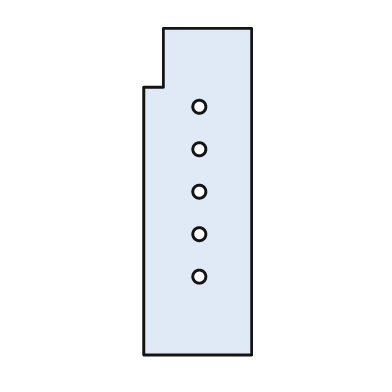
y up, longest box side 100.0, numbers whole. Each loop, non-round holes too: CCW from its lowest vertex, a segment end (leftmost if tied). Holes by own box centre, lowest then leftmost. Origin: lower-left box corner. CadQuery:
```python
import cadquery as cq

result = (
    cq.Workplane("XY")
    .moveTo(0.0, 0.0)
    .lineTo(33.0, 0.0)
    .lineTo(33.0, 100.0)
    .lineTo(6.0, 100.0)
    .lineTo(6.0, 82.0)
    .lineTo(0.0, 82.0)
    .close()
    .moveTo(17.0, 24.0)
    .circle(2.0)
    .moveTo(17.0, 37.0)
    .circle(2.0)
    .moveTo(17.0, 50.0)
    .circle(2.0)
    .moveTo(17.0, 63.0)
    .circle(2.0)
    .moveTo(17.0, 76.0)
    .circle(2.0)
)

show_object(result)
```